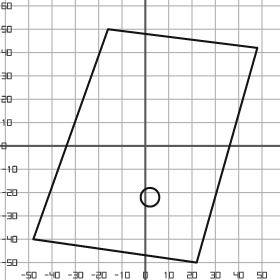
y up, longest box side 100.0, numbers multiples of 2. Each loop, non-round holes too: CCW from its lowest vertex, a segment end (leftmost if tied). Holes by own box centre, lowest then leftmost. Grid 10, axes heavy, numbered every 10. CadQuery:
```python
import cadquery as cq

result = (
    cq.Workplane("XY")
    .moveTo(22.0, -50.0)
    .lineTo(48.0, 42.0)
    .lineTo(-16.0, 50.0)
    .lineTo(-48.0, -40.0)
    .close()
    .moveTo(2.0, -22.0)
    .circle(4.0)
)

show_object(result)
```